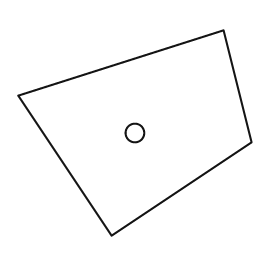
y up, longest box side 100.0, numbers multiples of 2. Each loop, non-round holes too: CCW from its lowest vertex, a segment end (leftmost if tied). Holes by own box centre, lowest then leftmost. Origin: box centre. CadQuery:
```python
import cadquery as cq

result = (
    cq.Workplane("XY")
    .moveTo(-10.0, -44.0)
    .lineTo(50.0, -4.0)
    .lineTo(38.0, 44.0)
    .lineTo(-50.0, 16.0)
    .close()
    .moveTo(0.0, 0.0)
    .circle(4.0)
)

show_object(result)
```